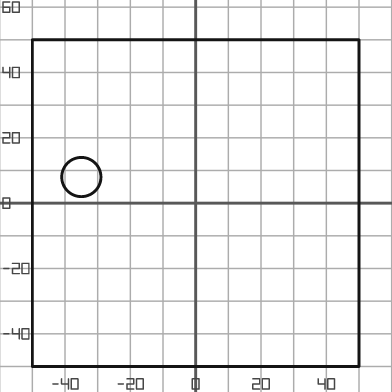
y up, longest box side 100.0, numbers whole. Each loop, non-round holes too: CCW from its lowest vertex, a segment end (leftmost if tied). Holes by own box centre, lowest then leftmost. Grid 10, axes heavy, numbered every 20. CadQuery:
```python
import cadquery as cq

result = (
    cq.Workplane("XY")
    .moveTo(-50.0, -50.0)
    .lineTo(50.0, -50.0)
    .lineTo(50.0, 50.0)
    .lineTo(-50.0, 50.0)
    .close()
    .moveTo(-35.0, 8.0)
    .circle(6.0)
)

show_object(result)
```